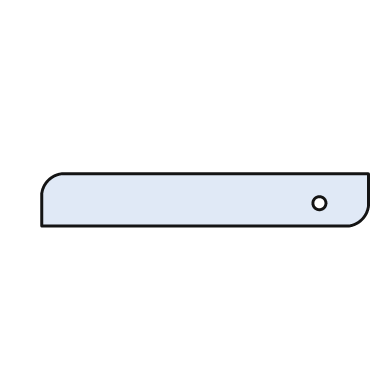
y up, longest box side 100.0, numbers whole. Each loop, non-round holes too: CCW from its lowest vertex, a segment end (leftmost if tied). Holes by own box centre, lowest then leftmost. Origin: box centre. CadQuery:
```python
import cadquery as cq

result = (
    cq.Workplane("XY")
    .moveTo(-50.0, -8.0)
    .lineTo(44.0, -8.0)
    .threePointArc((48.0, -6.0), (50.0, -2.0))
    .lineTo(50.0, 8.0)
    .lineTo(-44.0, 8.0)
    .threePointArc((-48.0, 6.0), (-50.0, 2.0))
    .close()
    .moveTo(35.0, -1.0)
    .circle(2.0)
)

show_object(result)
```